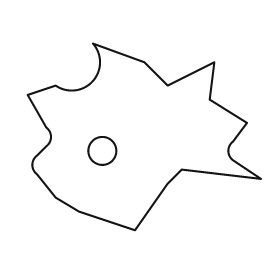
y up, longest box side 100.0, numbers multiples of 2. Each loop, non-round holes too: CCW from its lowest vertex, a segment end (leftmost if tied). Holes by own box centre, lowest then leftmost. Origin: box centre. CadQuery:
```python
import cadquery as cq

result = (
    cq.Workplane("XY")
    .moveTo(-4.0, -40.0)
    .lineTo(10.0, -20.0)
    .lineTo(16.0, -14.0)
    .lineTo(50.0, -18.0)
    .lineTo(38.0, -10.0)
    .threePointArc((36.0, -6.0), (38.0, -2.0))
    .lineTo(44.0, 6.0)
    .lineTo(28.0, 16.0)
    .lineTo(30.0, 32.0)
    .lineTo(10.0, 22.0)
    .lineTo(0.0, 32.0)
    .lineTo(-22.0, 40.0)
    .threePointArc((-22.0, 24.0), (-38.0, 22.0))
    .lineTo(-50.0, 18.0)
    .lineTo(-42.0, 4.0)
    .threePointArc((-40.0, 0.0), (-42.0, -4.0))
    .lineTo(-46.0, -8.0)
    .threePointArc((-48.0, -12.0), (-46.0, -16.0))
    .lineTo(-38.0, -26.0)
    .lineTo(-28.0, -32.0)
    .close()
    .moveTo(-18.0, -6.0)
    .circle(6.0)
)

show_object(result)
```